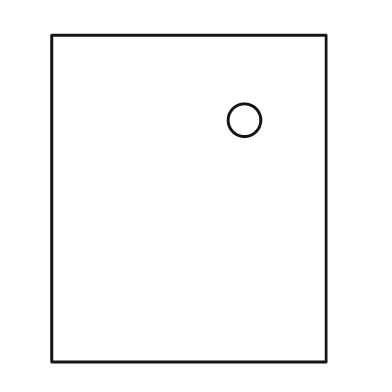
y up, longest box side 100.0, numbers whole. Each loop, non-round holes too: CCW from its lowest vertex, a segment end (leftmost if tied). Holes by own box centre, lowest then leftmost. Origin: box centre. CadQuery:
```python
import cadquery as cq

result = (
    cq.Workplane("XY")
    .moveTo(-42.0, -50.0)
    .lineTo(42.0, -50.0)
    .lineTo(42.0, 50.0)
    .lineTo(-42.0, 50.0)
    .close()
    .moveTo(17.0, 24.0)
    .circle(5.0)
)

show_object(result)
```